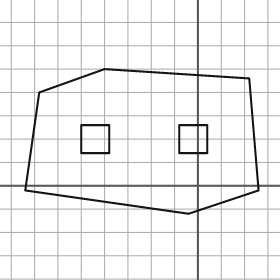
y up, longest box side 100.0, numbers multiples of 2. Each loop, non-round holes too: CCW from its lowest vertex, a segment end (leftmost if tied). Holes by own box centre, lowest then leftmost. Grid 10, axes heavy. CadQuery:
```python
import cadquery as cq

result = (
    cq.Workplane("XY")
    .moveTo(-4.0, -12.0)
    .lineTo(26.0, -2.0)
    .lineTo(22.0, 46.0)
    .lineTo(-40.0, 50.0)
    .lineTo(-68.0, 40.0)
    .lineTo(-74.0, -2.0)
    .close()
    .moveTo(-50.0, 14.0)
    .lineTo(-38.0, 14.0)
    .lineTo(-38.0, 26.0)
    .lineTo(-50.0, 26.0)
    .close()
    .moveTo(-8.0, 14.0)
    .lineTo(4.0, 14.0)
    .lineTo(4.0, 26.0)
    .lineTo(-8.0, 26.0)
    .close()
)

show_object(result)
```